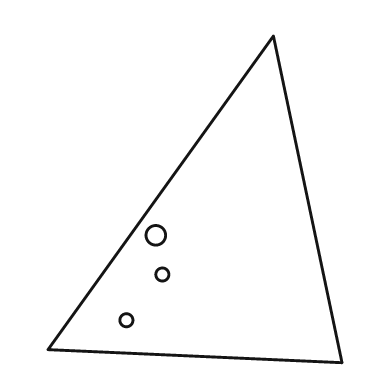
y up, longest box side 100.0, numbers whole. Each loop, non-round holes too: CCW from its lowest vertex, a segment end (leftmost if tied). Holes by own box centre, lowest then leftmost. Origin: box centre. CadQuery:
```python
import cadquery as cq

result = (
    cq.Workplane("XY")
    .moveTo(45.0, -50.0)
    .lineTo(24.0, 50.0)
    .lineTo(-45.0, -46.0)
    .close()
    .moveTo(-21.0, -37.0)
    .circle(2.0)
    .moveTo(-10.0, -23.0)
    .circle(2.0)
    .moveTo(-12.0, -11.0)
    .circle(3.0)
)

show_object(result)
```